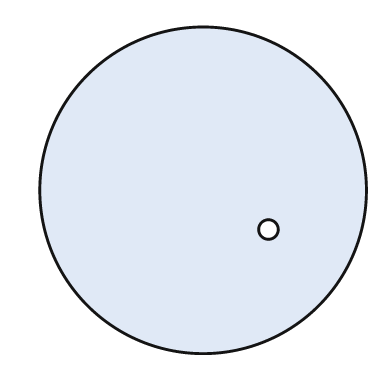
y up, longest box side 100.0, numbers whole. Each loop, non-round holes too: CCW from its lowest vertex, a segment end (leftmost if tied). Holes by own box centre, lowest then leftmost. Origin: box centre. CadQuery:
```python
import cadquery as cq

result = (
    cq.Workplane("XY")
    .moveTo(0.0, 0.0)
    .circle(50.0)
    .moveTo(20.0, -12.0)
    .circle(3.0)
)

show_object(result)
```